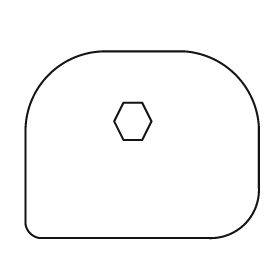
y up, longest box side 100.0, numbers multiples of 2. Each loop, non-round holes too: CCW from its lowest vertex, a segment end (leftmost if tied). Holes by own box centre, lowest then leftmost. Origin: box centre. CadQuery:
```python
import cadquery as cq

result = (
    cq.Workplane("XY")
    .moveTo(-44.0, -40.0)
    .lineTo(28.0, -40.0)
    .threePointArc((44.0, -34.0), (50.0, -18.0))
    .lineTo(50.0, 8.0)
    .threePointArc((40.0, 30.0), (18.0, 40.0))
    .lineTo(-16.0, 40.0)
    .threePointArc((-40.0, 30.0), (-50.0, 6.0))
    .lineTo(-50.0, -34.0)
    .threePointArc((-48.0, -38.0), (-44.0, -40.0))
    .close()
    .moveTo(-8.0, 2.0)
    .lineTo(0.0, 2.0)
    .lineTo(4.0, 10.0)
    .lineTo(0.0, 18.0)
    .lineTo(-8.0, 18.0)
    .lineTo(-12.0, 10.0)
    .close()
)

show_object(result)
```